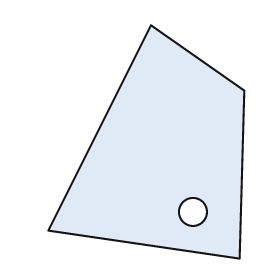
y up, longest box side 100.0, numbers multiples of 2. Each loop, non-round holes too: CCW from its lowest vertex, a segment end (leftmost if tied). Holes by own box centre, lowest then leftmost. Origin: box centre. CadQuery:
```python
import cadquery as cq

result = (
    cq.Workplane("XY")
    .moveTo(40.0, -50.0)
    .lineTo(42.0, 22.0)
    .lineTo(2.0, 50.0)
    .lineTo(-42.0, -38.0)
    .close()
    .moveTo(20.0, -30.0)
    .circle(6.0)
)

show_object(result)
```